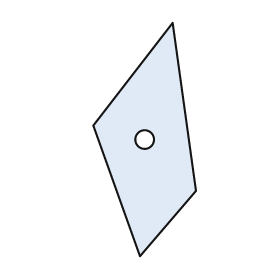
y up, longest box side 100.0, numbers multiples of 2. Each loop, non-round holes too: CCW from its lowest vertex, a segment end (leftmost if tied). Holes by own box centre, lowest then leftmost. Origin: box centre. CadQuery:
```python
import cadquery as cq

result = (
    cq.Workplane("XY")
    .moveTo(-2.0, -50.0)
    .lineTo(22.0, -22.0)
    .lineTo(12.0, 50.0)
    .lineTo(-22.0, 6.0)
    .close()
    .moveTo(0.0, 0.0)
    .circle(4.0)
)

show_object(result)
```